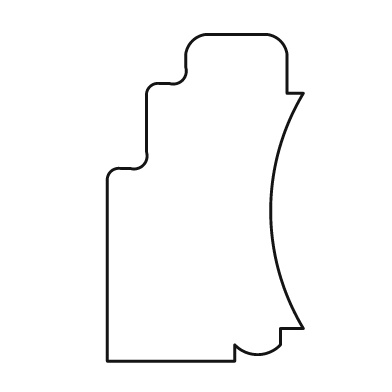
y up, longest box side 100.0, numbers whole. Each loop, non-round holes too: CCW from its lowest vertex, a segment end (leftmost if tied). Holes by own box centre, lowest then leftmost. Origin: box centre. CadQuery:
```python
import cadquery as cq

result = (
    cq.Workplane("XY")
    .moveTo(-30.0, -50.0)
    .lineTo(9.0, -50.0)
    .lineTo(9.0, -45.0)
    .threePointArc((16.0, -48.0), (23.0, -45.0))
    .lineTo(23.0, -40.0)
    .lineTo(30.0, -40.0)
    .threePointArc((20.0, -4.0), (30.0, 32.0))
    .lineTo(25.0, 32.0)
    .lineTo(25.0, 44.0)
    .threePointArc((23.0, 48.0), (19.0, 50.0))
    .lineTo(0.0, 50.0)
    .threePointArc((-4.0, 48.0), (-6.0, 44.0))
    .lineTo(-6.0, 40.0)
    .threePointArc((-7.0, 36.0), (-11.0, 35.0))
    .lineTo(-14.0, 35.0)
    .threePointArc((-17.0, 34.0), (-18.0, 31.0))
    .lineTo(-18.0, 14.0)
    .threePointArc((-19.0, 10.0), (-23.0, 9.0))
    .lineTo(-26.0, 9.0)
    .threePointArc((-29.0, 8.0), (-30.0, 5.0))
    .close()
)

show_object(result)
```